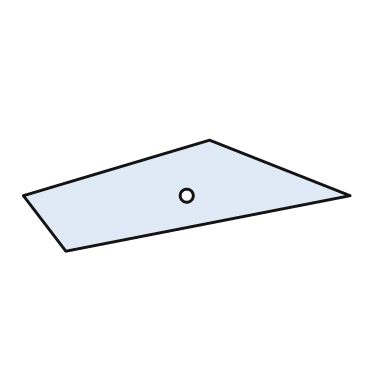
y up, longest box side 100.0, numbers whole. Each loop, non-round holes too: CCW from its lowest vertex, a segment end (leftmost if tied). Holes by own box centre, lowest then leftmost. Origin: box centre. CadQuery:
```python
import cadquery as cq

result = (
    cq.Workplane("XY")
    .moveTo(-37.0, -17.0)
    .lineTo(50.0, 0.0)
    .lineTo(7.0, 17.0)
    .lineTo(-50.0, 0.0)
    .close()
    .moveTo(0.0, 0.0)
    .circle(2.0)
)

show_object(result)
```